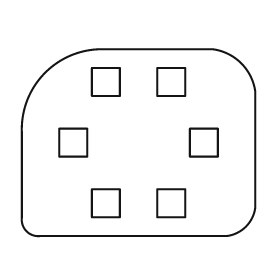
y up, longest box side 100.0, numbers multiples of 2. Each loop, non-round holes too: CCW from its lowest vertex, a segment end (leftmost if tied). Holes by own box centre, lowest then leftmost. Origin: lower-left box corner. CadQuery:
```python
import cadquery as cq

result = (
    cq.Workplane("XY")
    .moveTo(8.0, 0.0)
    .lineTo(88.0, 0.0)
    .threePointArc((96.0, 4.0), (100.0, 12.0))
    .lineTo(100.0, 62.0)
    .threePointArc((94.0, 74.0), (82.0, 80.0))
    .lineTo(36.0, 80.0)
    .threePointArc((10.0, 70.0), (0.0, 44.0))
    .lineTo(0.0, 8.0)
    .threePointArc((2.0, 2.0), (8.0, 0.0))
    .close()
    .moveTo(30.0, 8.0)
    .lineTo(42.0, 8.0)
    .lineTo(42.0, 20.0)
    .lineTo(30.0, 20.0)
    .close()
    .moveTo(58.0, 8.0)
    .lineTo(70.0, 8.0)
    .lineTo(70.0, 20.0)
    .lineTo(58.0, 20.0)
    .close()
    .moveTo(16.0, 34.0)
    .lineTo(28.0, 34.0)
    .lineTo(28.0, 46.0)
    .lineTo(16.0, 46.0)
    .close()
    .moveTo(72.0, 34.0)
    .lineTo(84.0, 34.0)
    .lineTo(84.0, 46.0)
    .lineTo(72.0, 46.0)
    .close()
    .moveTo(30.0, 60.0)
    .lineTo(42.0, 60.0)
    .lineTo(42.0, 72.0)
    .lineTo(30.0, 72.0)
    .close()
    .moveTo(58.0, 60.0)
    .lineTo(70.0, 60.0)
    .lineTo(70.0, 72.0)
    .lineTo(58.0, 72.0)
    .close()
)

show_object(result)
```